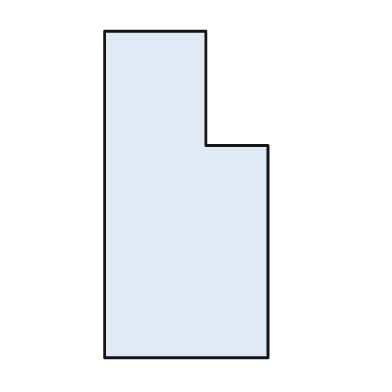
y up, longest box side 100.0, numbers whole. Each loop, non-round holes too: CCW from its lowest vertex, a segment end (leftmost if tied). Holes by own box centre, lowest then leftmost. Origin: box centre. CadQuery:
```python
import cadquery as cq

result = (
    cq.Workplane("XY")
    .moveTo(-25.0, -50.0)
    .lineTo(25.0, -50.0)
    .lineTo(25.0, 15.0)
    .lineTo(6.0, 15.0)
    .lineTo(6.0, 50.0)
    .lineTo(-25.0, 50.0)
    .close()
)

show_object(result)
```